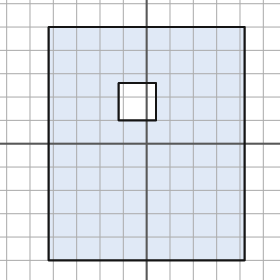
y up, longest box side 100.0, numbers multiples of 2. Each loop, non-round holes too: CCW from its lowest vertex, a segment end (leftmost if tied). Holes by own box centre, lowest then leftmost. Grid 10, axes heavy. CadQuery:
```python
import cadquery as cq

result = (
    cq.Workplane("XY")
    .moveTo(-42.0, -50.0)
    .lineTo(42.0, -50.0)
    .lineTo(42.0, 50.0)
    .lineTo(-42.0, 50.0)
    .close()
    .moveTo(-12.0, 10.0)
    .lineTo(4.0, 10.0)
    .lineTo(4.0, 26.0)
    .lineTo(-12.0, 26.0)
    .close()
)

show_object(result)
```